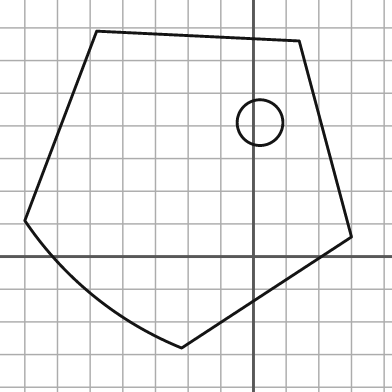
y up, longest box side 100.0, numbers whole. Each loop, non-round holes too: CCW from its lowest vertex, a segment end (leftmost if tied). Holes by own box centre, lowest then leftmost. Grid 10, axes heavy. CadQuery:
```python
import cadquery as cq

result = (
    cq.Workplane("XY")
    .moveTo(-22.0, -28.0)
    .lineTo(30.0, 6.0)
    .lineTo(14.0, 66.0)
    .lineTo(-48.0, 69.0)
    .lineTo(-70.0, 11.0)
    .threePointArc((-49.0, -12.0), (-22.0, -28.0))
    .close()
    .moveTo(2.0, 41.0)
    .circle(7.0)
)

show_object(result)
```